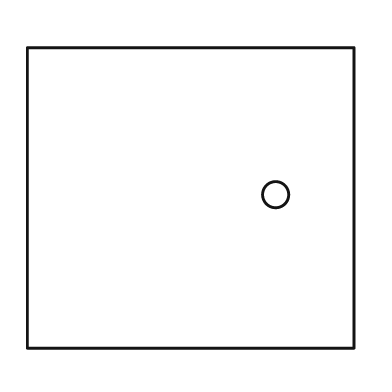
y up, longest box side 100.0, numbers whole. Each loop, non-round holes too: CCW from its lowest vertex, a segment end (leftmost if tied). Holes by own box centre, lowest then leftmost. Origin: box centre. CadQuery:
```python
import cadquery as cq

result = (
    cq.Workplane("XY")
    .moveTo(-50.0, -46.0)
    .lineTo(50.0, -46.0)
    .lineTo(50.0, 46.0)
    .lineTo(-50.0, 46.0)
    .close()
    .moveTo(26.0, 1.0)
    .circle(4.0)
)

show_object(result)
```